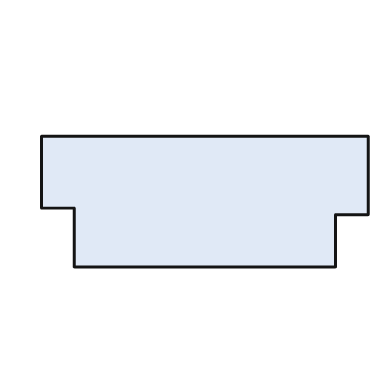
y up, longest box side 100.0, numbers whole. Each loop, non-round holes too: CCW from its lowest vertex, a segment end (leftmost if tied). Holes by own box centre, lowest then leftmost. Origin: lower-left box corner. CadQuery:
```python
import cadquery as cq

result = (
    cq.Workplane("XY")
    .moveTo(10.0, 0.0)
    .lineTo(90.0, 0.0)
    .lineTo(90.0, 16.0)
    .lineTo(100.0, 16.0)
    .lineTo(100.0, 40.0)
    .lineTo(0.0, 40.0)
    .lineTo(0.0, 18.0)
    .lineTo(10.0, 18.0)
    .close()
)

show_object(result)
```